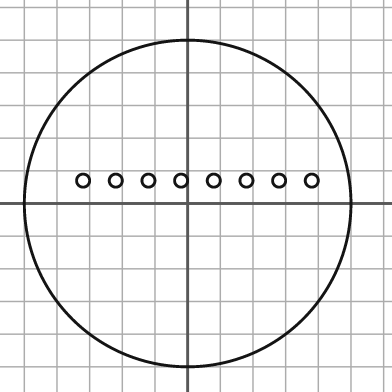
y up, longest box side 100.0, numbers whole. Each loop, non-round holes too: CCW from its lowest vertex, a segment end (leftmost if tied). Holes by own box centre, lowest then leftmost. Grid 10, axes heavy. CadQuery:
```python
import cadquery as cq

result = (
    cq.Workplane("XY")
    .moveTo(0.0, 0.0)
    .circle(50.0)
    .moveTo(-32.0, 7.0)
    .circle(2.0)
    .moveTo(-22.0, 7.0)
    .circle(2.0)
    .moveTo(-12.0, 7.0)
    .circle(2.0)
    .moveTo(-2.0, 7.0)
    .circle(2.0)
    .moveTo(8.0, 7.0)
    .circle(2.0)
    .moveTo(18.0, 7.0)
    .circle(2.0)
    .moveTo(28.0, 7.0)
    .circle(2.0)
    .moveTo(38.0, 7.0)
    .circle(2.0)
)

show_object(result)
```